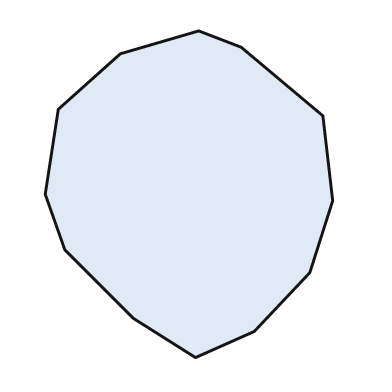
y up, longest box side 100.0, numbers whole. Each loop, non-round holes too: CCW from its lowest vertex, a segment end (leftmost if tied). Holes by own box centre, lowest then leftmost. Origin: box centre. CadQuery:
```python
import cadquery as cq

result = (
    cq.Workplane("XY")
    .moveTo(2.0, -50.0)
    .lineTo(20.0, -42.0)
    .lineTo(37.0, -24.0)
    .lineTo(44.0, -2.0)
    .lineTo(41.0, 24.0)
    .lineTo(16.0, 45.0)
    .lineTo(3.0, 50.0)
    .lineTo(-21.0, 43.0)
    .lineTo(-40.0, 26.0)
    .lineTo(-44.0, 0.0)
    .lineTo(-38.0, -17.0)
    .lineTo(-17.0, -38.0)
    .close()
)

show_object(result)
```